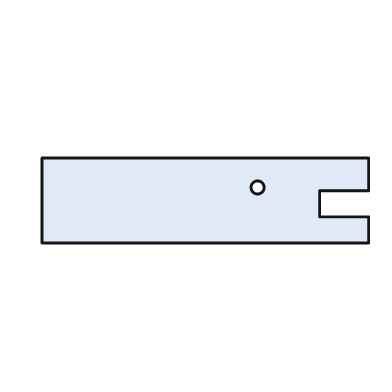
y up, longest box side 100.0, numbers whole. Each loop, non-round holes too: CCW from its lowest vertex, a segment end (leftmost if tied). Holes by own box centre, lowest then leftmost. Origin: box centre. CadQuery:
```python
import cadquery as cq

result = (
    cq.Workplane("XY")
    .moveTo(-50.0, -13.0)
    .lineTo(50.0, -13.0)
    .lineTo(50.0, -5.0)
    .lineTo(35.0, -5.0)
    .lineTo(35.0, 3.0)
    .lineTo(50.0, 3.0)
    .lineTo(50.0, 13.0)
    .lineTo(-50.0, 13.0)
    .close()
    .moveTo(16.0, 4.0)
    .circle(2.0)
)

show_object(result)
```